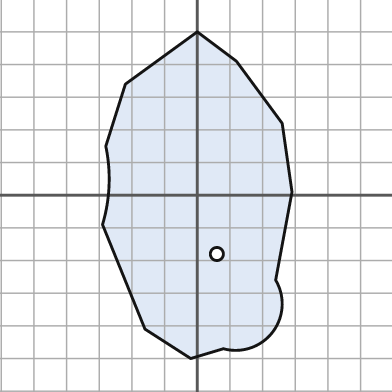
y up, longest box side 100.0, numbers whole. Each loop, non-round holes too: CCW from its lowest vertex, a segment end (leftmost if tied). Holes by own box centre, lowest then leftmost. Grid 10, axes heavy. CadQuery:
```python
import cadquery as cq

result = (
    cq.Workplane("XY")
    .moveTo(-2.0, -50.0)
    .lineTo(8.0, -47.0)
    .threePointArc((23.0, -42.0), (24.0, -26.0))
    .lineTo(29.0, 1.0)
    .lineTo(26.0, 22.0)
    .lineTo(12.0, 41.0)
    .lineTo(0.0, 50.0)
    .lineTo(-22.0, 34.0)
    .lineTo(-28.0, 15.0)
    .threePointArc((-27.0, 3.0), (-29.0, -9.0))
    .lineTo(-16.0, -41.0)
    .close()
    .moveTo(6.0, -18.0)
    .circle(2.0)
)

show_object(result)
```